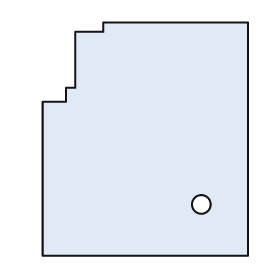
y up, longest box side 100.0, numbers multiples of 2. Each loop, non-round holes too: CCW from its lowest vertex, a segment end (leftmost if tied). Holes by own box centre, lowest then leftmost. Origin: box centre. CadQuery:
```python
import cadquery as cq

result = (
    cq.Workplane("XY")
    .moveTo(-44.0, -50.0)
    .lineTo(44.0, -50.0)
    .lineTo(44.0, 50.0)
    .lineTo(-18.0, 50.0)
    .lineTo(-18.0, 46.0)
    .lineTo(-30.0, 46.0)
    .lineTo(-30.0, 22.0)
    .lineTo(-34.0, 22.0)
    .lineTo(-34.0, 16.0)
    .lineTo(-44.0, 16.0)
    .close()
    .moveTo(24.0, -28.0)
    .circle(4.0)
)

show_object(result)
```